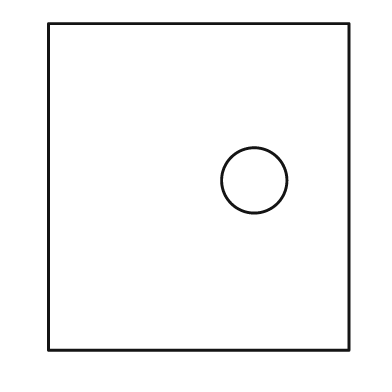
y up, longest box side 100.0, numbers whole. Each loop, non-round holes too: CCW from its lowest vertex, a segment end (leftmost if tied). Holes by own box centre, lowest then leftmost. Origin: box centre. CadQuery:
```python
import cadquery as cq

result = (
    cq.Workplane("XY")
    .moveTo(-46.0, -50.0)
    .lineTo(46.0, -50.0)
    .lineTo(46.0, 50.0)
    .lineTo(-46.0, 50.0)
    .close()
    .moveTo(17.0, 2.0)
    .circle(10.0)
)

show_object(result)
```